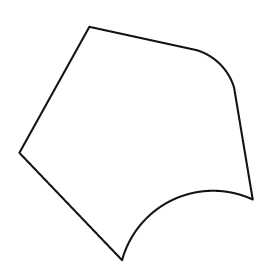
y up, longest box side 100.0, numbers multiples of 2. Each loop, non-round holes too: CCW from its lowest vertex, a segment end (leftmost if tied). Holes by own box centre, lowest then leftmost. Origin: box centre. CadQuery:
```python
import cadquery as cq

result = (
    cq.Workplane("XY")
    .moveTo(-6.0, -50.0)
    .threePointArc((16.0, -24.0), (50.0, -24.0))
    .lineTo(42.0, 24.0)
    .threePointArc((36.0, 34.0), (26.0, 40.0))
    .lineTo(-20.0, 50.0)
    .lineTo(-50.0, -4.0)
    .close()
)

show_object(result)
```